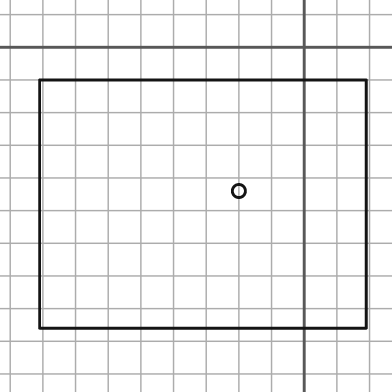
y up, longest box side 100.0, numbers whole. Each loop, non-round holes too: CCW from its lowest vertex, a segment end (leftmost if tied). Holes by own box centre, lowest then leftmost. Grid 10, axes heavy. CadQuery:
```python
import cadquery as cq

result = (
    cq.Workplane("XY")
    .moveTo(-81.0, -86.0)
    .lineTo(19.0, -86.0)
    .lineTo(19.0, -10.0)
    .lineTo(-81.0, -10.0)
    .close()
    .moveTo(-20.0, -44.0)
    .circle(2.0)
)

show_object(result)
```